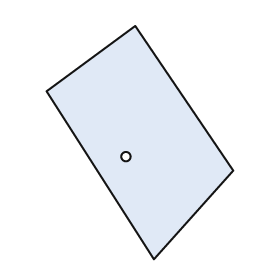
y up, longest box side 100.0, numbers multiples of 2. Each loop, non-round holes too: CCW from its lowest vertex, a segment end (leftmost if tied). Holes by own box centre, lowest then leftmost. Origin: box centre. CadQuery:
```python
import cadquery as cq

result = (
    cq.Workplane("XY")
    .moveTo(6.0, -50.0)
    .lineTo(40.0, -12.0)
    .lineTo(-2.0, 50.0)
    .lineTo(-40.0, 22.0)
    .close()
    .moveTo(-6.0, -6.0)
    .circle(2.0)
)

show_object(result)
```